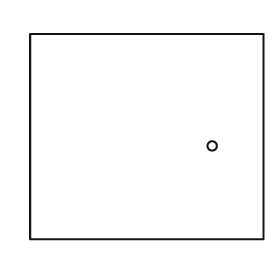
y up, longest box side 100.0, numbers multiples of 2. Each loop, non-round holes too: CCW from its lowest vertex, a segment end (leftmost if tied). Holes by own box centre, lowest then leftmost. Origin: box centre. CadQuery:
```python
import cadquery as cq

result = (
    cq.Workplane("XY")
    .moveTo(-50.0, -44.0)
    .lineTo(50.0, -44.0)
    .lineTo(50.0, 44.0)
    .lineTo(-50.0, 44.0)
    .close()
    .moveTo(28.0, -4.0)
    .circle(2.0)
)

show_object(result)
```